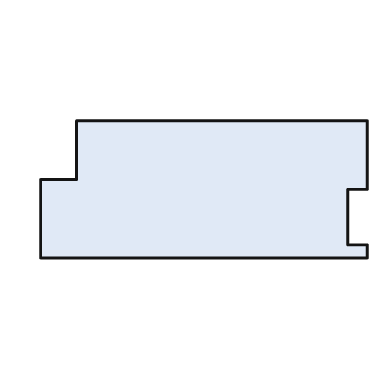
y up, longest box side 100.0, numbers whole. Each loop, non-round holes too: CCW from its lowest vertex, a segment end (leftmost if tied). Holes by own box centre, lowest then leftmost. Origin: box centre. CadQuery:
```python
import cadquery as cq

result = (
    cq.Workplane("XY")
    .moveTo(-50.0, -21.0)
    .lineTo(50.0, -21.0)
    .lineTo(50.0, -17.0)
    .lineTo(44.0, -17.0)
    .lineTo(44.0, 0.0)
    .lineTo(50.0, 0.0)
    .lineTo(50.0, 21.0)
    .lineTo(-39.0, 21.0)
    .lineTo(-39.0, 3.0)
    .lineTo(-50.0, 3.0)
    .close()
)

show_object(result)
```